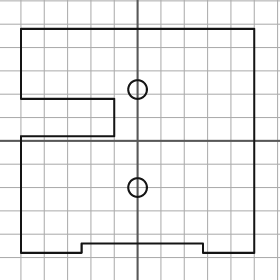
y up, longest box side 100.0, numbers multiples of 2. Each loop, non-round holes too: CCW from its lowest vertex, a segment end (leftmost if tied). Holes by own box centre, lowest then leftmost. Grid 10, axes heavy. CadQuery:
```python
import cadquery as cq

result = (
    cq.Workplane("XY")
    .moveTo(-50.0, -48.0)
    .lineTo(-24.0, -48.0)
    .lineTo(-24.0, -44.0)
    .lineTo(28.0, -44.0)
    .lineTo(28.0, -48.0)
    .lineTo(50.0, -48.0)
    .lineTo(50.0, 48.0)
    .lineTo(-50.0, 48.0)
    .lineTo(-50.0, 18.0)
    .lineTo(-10.0, 18.0)
    .lineTo(-10.0, 2.0)
    .lineTo(-50.0, 2.0)
    .close()
    .moveTo(0.0, -20.0)
    .circle(4.0)
    .moveTo(0.0, 22.0)
    .circle(4.0)
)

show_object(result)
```